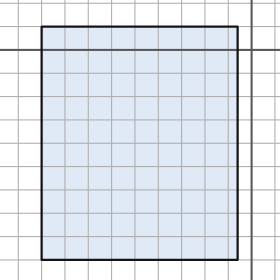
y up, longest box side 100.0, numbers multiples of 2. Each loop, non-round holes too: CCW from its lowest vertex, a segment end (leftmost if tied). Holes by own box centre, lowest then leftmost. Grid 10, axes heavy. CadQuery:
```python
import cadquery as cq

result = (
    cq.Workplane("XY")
    .moveTo(-90.0, -90.0)
    .lineTo(-6.0, -90.0)
    .lineTo(-6.0, 10.0)
    .lineTo(-90.0, 10.0)
    .close()
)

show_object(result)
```